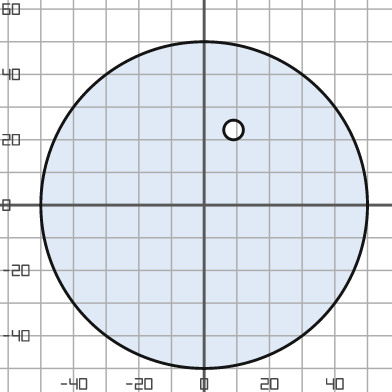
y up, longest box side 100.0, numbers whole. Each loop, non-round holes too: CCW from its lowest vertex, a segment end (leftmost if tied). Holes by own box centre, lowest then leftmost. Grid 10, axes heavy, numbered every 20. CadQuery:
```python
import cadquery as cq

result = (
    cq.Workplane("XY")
    .moveTo(0.0, 0.0)
    .circle(50.0)
    .moveTo(9.0, 23.0)
    .circle(3.0)
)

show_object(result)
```